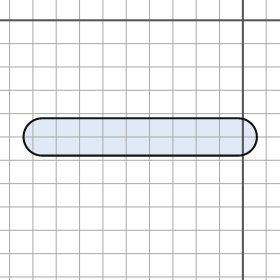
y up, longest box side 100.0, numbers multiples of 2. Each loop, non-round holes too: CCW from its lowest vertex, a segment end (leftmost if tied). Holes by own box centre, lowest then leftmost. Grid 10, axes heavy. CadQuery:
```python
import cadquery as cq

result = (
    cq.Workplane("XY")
    .moveTo(-86.0, -58.0)
    .lineTo(-2.0, -58.0)
    .threePointArc((6.0, -50.0), (-2.0, -42.0))
    .lineTo(-86.0, -42.0)
    .threePointArc((-94.0, -50.0), (-86.0, -58.0))
    .close()
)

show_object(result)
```